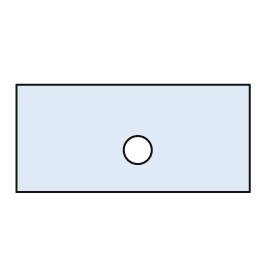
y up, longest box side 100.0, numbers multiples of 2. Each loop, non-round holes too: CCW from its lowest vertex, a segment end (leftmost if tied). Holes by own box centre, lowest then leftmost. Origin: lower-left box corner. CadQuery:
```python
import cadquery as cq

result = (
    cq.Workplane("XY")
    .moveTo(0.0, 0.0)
    .lineTo(100.0, 0.0)
    .lineTo(100.0, 46.0)
    .lineTo(0.0, 46.0)
    .close()
    .moveTo(52.0, 18.0)
    .circle(6.0)
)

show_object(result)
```